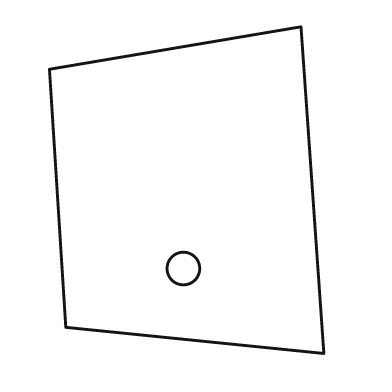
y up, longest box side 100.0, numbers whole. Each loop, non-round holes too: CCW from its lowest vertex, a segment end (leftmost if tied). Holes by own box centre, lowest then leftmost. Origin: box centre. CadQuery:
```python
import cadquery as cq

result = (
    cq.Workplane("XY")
    .moveTo(42.0, -50.0)
    .lineTo(35.0, 50.0)
    .lineTo(-42.0, 37.0)
    .lineTo(-37.0, -42.0)
    .close()
    .moveTo(-1.0, -24.0)
    .circle(5.0)
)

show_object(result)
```